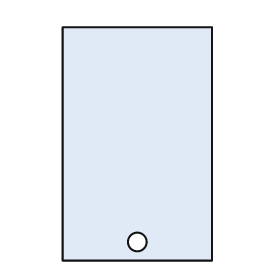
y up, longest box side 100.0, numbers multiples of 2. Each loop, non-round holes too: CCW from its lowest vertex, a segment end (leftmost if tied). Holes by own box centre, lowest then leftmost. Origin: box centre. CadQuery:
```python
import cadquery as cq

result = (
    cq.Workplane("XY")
    .moveTo(-32.0, -50.0)
    .lineTo(32.0, -50.0)
    .lineTo(32.0, 50.0)
    .lineTo(-32.0, 50.0)
    .close()
    .moveTo(0.0, -42.0)
    .circle(4.0)
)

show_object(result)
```